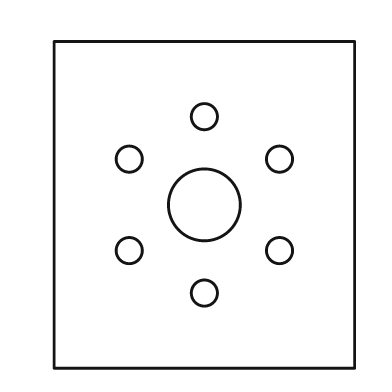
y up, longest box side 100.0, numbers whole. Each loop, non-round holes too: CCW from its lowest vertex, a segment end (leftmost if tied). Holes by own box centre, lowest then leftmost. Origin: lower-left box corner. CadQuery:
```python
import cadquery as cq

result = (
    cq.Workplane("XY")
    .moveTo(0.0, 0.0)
    .lineTo(92.0, 0.0)
    .lineTo(92.0, 100.0)
    .lineTo(0.0, 100.0)
    .close()
    .moveTo(46.0, 23.0)
    .circle(4.0)
    .moveTo(23.0, 36.0)
    .circle(4.0)
    .moveTo(69.0, 36.0)
    .circle(4.0)
    .moveTo(46.0, 50.0)
    .circle(11.0)
    .moveTo(23.0, 64.0)
    .circle(4.0)
    .moveTo(69.0, 64.0)
    .circle(4.0)
    .moveTo(46.0, 77.0)
    .circle(4.0)
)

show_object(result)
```